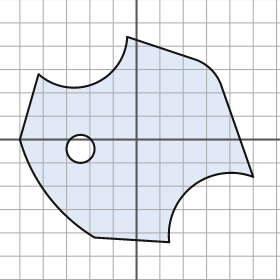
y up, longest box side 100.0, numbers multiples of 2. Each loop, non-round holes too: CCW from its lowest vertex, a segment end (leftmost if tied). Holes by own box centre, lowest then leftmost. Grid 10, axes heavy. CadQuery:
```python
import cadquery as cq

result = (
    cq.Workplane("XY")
    .moveTo(14.0, -44.0)
    .threePointArc((24.0, -20.0), (50.0, -16.0))
    .lineTo(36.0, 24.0)
    .threePointArc((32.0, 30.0), (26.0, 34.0))
    .lineTo(-4.0, 44.0)
    .threePointArc((-18.0, 24.0), (-42.0, 28.0))
    .lineTo(-50.0, 0.0)
    .threePointArc((-38.0, -24.0), (-18.0, -42.0))
    .close()
    .moveTo(-24.0, -4.0)
    .circle(6.0)
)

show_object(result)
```